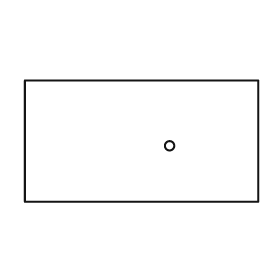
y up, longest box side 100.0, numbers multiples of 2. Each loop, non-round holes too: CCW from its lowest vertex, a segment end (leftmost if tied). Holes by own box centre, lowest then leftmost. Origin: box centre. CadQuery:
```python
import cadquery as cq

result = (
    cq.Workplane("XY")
    .moveTo(-50.0, -26.0)
    .lineTo(50.0, -26.0)
    .lineTo(50.0, 26.0)
    .lineTo(-50.0, 26.0)
    .close()
    .moveTo(12.0, -2.0)
    .circle(2.0)
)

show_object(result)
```